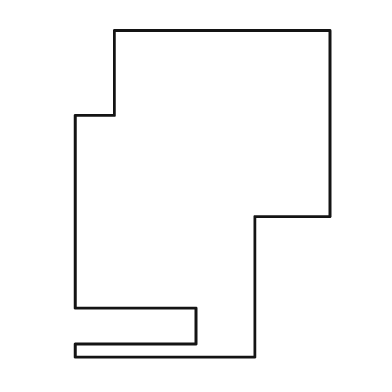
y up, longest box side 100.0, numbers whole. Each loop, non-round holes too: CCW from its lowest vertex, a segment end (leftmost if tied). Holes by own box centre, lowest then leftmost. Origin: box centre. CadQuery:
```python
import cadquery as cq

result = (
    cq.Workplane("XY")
    .moveTo(-39.0, -50.0)
    .lineTo(16.0, -50.0)
    .lineTo(16.0, -7.0)
    .lineTo(39.0, -7.0)
    .lineTo(39.0, 50.0)
    .lineTo(-27.0, 50.0)
    .lineTo(-27.0, 24.0)
    .lineTo(-39.0, 24.0)
    .lineTo(-39.0, -35.0)
    .lineTo(-2.0, -35.0)
    .lineTo(-2.0, -46.0)
    .lineTo(-39.0, -46.0)
    .close()
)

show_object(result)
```